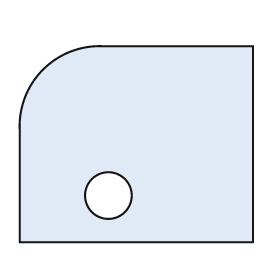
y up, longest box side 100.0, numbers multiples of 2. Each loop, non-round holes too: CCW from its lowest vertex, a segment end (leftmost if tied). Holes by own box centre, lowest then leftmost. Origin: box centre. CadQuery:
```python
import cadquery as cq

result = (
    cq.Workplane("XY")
    .moveTo(-50.0, -42.0)
    .lineTo(50.0, -42.0)
    .lineTo(50.0, 42.0)
    .lineTo(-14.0, 42.0)
    .threePointArc((-40.0, 32.0), (-50.0, 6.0))
    .close()
    .moveTo(-12.0, -22.0)
    .circle(10.0)
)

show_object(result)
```